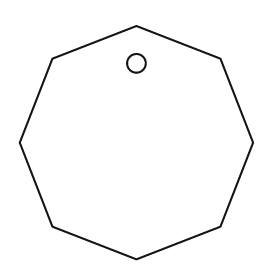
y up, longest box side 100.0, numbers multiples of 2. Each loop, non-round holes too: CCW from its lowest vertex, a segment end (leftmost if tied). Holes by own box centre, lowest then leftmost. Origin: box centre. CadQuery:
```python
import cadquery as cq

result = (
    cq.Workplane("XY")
    .moveTo(0.0, -50.0)
    .lineTo(36.0, -36.0)
    .lineTo(50.0, 0.0)
    .lineTo(36.0, 36.0)
    .lineTo(0.0, 50.0)
    .lineTo(-36.0, 36.0)
    .lineTo(-50.0, 0.0)
    .lineTo(-36.0, -36.0)
    .close()
    .moveTo(0.0, 34.0)
    .circle(4.0)
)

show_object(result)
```